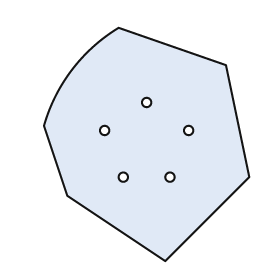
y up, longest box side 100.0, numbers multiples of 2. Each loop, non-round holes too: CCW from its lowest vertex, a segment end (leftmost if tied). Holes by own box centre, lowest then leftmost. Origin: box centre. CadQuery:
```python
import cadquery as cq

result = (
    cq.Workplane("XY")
    .moveTo(8.0, -50.0)
    .lineTo(44.0, -14.0)
    .lineTo(34.0, 34.0)
    .lineTo(-12.0, 50.0)
    .threePointArc((-32.0, 32.0), (-44.0, 8.0))
    .lineTo(-34.0, -22.0)
    .close()
    .moveTo(-10.0, -14.0)
    .circle(2.0)
    .moveTo(10.0, -14.0)
    .circle(2.0)
    .moveTo(-18.0, 6.0)
    .circle(2.0)
    .moveTo(18.0, 6.0)
    .circle(2.0)
    .moveTo(0.0, 18.0)
    .circle(2.0)
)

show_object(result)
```